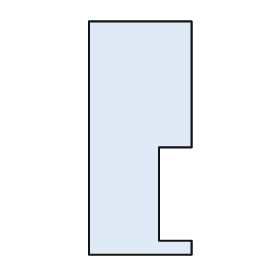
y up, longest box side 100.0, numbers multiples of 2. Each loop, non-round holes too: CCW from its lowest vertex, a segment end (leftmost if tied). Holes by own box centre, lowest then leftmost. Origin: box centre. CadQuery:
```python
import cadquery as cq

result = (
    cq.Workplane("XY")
    .moveTo(-22.0, -50.0)
    .lineTo(22.0, -50.0)
    .lineTo(22.0, -44.0)
    .lineTo(8.0, -44.0)
    .lineTo(8.0, -4.0)
    .lineTo(22.0, -4.0)
    .lineTo(22.0, 50.0)
    .lineTo(-22.0, 50.0)
    .close()
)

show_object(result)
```